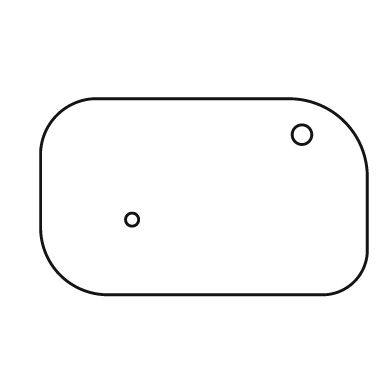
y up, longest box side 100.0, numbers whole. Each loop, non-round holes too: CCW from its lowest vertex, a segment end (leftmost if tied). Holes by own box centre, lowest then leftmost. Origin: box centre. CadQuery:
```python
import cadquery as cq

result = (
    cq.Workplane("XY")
    .moveTo(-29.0, -30.0)
    .lineTo(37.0, -30.0)
    .threePointArc((46.0, -26.0), (50.0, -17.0))
    .lineTo(50.0, 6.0)
    .threePointArc((43.0, 23.0), (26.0, 30.0))
    .lineTo(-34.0, 30.0)
    .threePointArc((-45.0, 25.0), (-50.0, 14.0))
    .lineTo(-50.0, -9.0)
    .threePointArc((-44.0, -24.0), (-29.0, -30.0))
    .close()
    .moveTo(-22.0, -7.0)
    .circle(2.0)
    .moveTo(30.0, 19.0)
    .circle(3.0)
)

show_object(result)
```